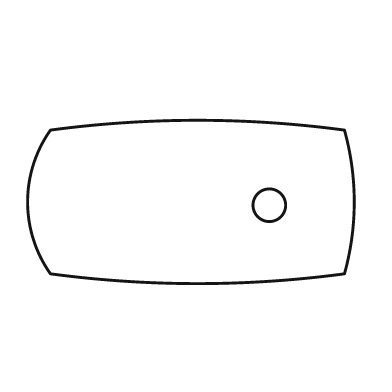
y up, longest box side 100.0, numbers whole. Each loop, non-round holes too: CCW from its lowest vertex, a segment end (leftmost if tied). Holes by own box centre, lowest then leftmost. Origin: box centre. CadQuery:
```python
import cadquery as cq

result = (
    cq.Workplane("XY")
    .moveTo(-43.0, -22.0)
    .threePointArc((2.0, -25.0), (47.0, -22.0))
    .threePointArc((50.0, 0.0), (47.0, 22.0))
    .threePointArc((2.0, 25.0), (-43.0, 22.0))
    .threePointArc((-50.0, 0.0), (-43.0, -22.0))
    .close()
    .moveTo(24.0, -1.0)
    .circle(5.0)
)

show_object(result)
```